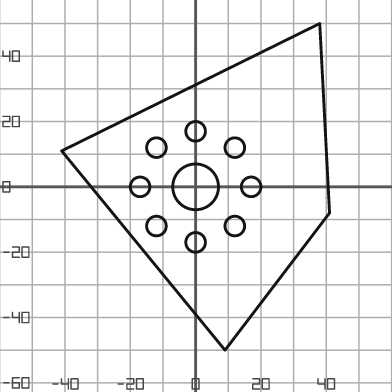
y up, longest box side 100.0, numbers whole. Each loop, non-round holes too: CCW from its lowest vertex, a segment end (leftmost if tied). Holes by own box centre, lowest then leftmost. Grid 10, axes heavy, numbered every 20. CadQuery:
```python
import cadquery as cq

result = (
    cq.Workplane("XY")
    .moveTo(9.0, -50.0)
    .lineTo(41.0, -8.0)
    .lineTo(38.0, 50.0)
    .lineTo(-41.0, 11.0)
    .close()
    .moveTo(0.0, -17.0)
    .circle(3.0)
    .moveTo(-12.0, -12.0)
    .circle(3.0)
    .moveTo(12.0, -12.0)
    .circle(3.0)
    .moveTo(-17.0, 0.0)
    .circle(3.0)
    .moveTo(0.0, 0.0)
    .circle(7.0)
    .moveTo(17.0, 0.0)
    .circle(3.0)
    .moveTo(-12.0, 12.0)
    .circle(3.0)
    .moveTo(12.0, 12.0)
    .circle(3.0)
    .moveTo(0.0, 17.0)
    .circle(3.0)
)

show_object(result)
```